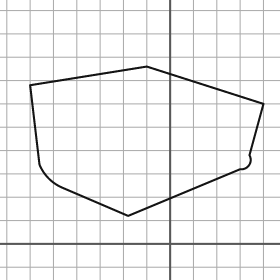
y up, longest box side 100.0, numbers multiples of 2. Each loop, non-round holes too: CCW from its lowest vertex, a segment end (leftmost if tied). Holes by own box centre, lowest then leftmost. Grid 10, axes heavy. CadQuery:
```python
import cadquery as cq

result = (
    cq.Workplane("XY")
    .moveTo(-18.0, 12.0)
    .lineTo(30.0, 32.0)
    .threePointArc((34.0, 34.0), (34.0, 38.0))
    .lineTo(40.0, 60.0)
    .lineTo(-10.0, 76.0)
    .lineTo(-60.0, 68.0)
    .lineTo(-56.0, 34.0)
    .threePointArc((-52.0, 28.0), (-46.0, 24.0))
    .close()
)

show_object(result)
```